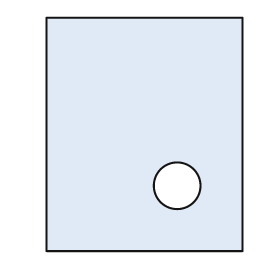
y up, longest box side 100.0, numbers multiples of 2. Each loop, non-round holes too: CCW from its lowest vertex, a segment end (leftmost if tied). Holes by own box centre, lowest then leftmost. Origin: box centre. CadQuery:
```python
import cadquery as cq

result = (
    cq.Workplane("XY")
    .moveTo(-42.0, -50.0)
    .lineTo(42.0, -50.0)
    .lineTo(42.0, 50.0)
    .lineTo(-42.0, 50.0)
    .close()
    .moveTo(14.0, -22.0)
    .circle(10.0)
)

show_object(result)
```